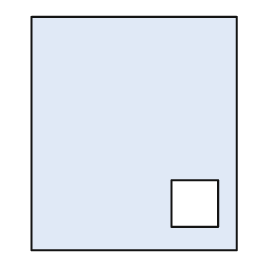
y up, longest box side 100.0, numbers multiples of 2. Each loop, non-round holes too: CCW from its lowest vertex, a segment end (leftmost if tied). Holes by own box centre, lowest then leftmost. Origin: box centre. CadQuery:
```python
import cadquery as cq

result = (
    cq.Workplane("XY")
    .moveTo(-44.0, -50.0)
    .lineTo(44.0, -50.0)
    .lineTo(44.0, 50.0)
    .lineTo(-44.0, 50.0)
    .close()
    .moveTo(16.0, -40.0)
    .lineTo(36.0, -40.0)
    .lineTo(36.0, -20.0)
    .lineTo(16.0, -20.0)
    .close()
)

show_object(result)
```